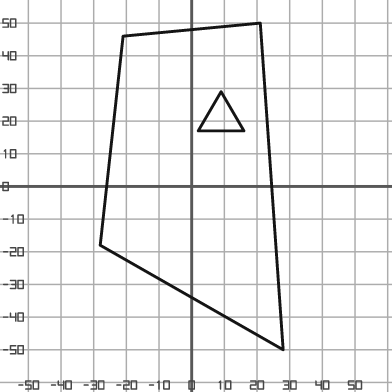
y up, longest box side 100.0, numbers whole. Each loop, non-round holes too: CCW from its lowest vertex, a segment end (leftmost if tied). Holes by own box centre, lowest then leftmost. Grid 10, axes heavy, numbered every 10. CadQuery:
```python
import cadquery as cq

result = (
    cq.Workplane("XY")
    .moveTo(28.0, -50.0)
    .lineTo(21.0, 50.0)
    .lineTo(-21.0, 46.0)
    .lineTo(-28.0, -18.0)
    .close()
    .moveTo(2.0, 17.0)
    .lineTo(16.0, 17.0)
    .lineTo(9.0, 29.0)
    .close()
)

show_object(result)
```